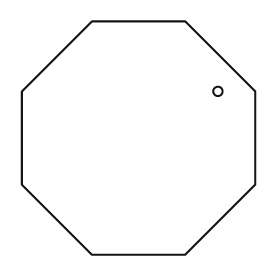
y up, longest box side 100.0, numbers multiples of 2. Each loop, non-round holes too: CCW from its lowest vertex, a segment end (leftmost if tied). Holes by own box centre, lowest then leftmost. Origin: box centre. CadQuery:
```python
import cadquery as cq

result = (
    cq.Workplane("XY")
    .moveTo(-20.0, -50.0)
    .lineTo(20.0, -50.0)
    .lineTo(50.0, -20.0)
    .lineTo(50.0, 20.0)
    .lineTo(20.0, 50.0)
    .lineTo(-20.0, 50.0)
    .lineTo(-50.0, 20.0)
    .lineTo(-50.0, -20.0)
    .close()
    .moveTo(34.0, 20.0)
    .circle(2.0)
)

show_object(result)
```